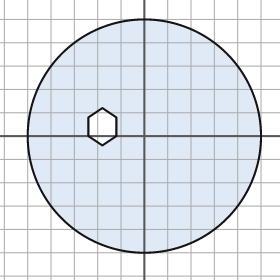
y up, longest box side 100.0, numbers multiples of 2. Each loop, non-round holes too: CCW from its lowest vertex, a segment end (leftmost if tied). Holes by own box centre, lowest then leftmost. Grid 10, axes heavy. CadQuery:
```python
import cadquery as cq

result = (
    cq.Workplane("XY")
    .moveTo(0.0, 0.0)
    .circle(50.0)
    .moveTo(-18.0, -4.0)
    .lineTo(-12.0, 0.0)
    .lineTo(-12.0, 8.0)
    .lineTo(-18.0, 12.0)
    .lineTo(-24.0, 8.0)
    .lineTo(-24.0, 0.0)
    .close()
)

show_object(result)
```